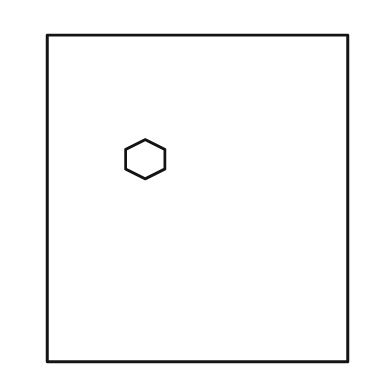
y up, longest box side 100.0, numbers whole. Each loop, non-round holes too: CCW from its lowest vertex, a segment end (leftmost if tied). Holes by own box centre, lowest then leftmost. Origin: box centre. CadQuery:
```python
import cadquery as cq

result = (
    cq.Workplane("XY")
    .moveTo(-46.0, -50.0)
    .lineTo(46.0, -50.0)
    .lineTo(46.0, 50.0)
    .lineTo(-46.0, 50.0)
    .close()
    .moveTo(-16.0, 6.0)
    .lineTo(-10.0, 9.0)
    .lineTo(-10.0, 15.0)
    .lineTo(-16.0, 18.0)
    .lineTo(-22.0, 15.0)
    .lineTo(-22.0, 9.0)
    .close()
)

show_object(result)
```